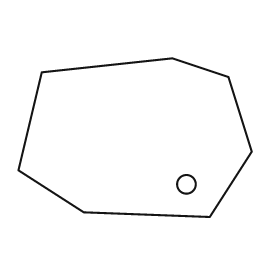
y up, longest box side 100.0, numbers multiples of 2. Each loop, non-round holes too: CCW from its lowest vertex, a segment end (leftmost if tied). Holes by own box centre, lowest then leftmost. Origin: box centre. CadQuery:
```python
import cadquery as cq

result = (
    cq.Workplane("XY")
    .moveTo(32.0, -34.0)
    .lineTo(50.0, -6.0)
    .lineTo(40.0, 26.0)
    .lineTo(16.0, 34.0)
    .lineTo(-40.0, 28.0)
    .lineTo(-50.0, -14.0)
    .lineTo(-22.0, -32.0)
    .close()
    .moveTo(22.0, -20.0)
    .circle(4.0)
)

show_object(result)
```